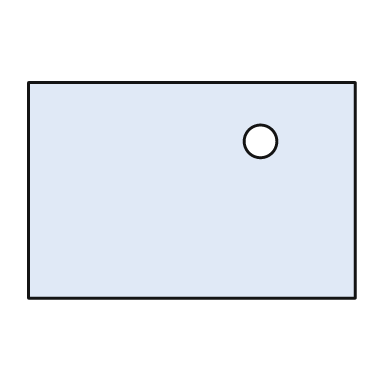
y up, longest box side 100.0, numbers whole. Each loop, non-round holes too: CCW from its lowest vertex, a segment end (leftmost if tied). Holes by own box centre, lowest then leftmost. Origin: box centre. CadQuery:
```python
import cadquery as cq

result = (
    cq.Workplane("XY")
    .moveTo(-50.0, -33.0)
    .lineTo(50.0, -33.0)
    .lineTo(50.0, 33.0)
    .lineTo(-50.0, 33.0)
    .close()
    .moveTo(21.0, 15.0)
    .circle(5.0)
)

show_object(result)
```